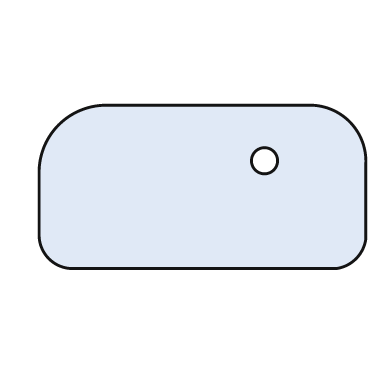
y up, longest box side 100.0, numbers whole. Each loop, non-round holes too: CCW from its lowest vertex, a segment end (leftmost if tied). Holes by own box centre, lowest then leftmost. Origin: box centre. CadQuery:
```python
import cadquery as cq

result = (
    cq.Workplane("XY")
    .moveTo(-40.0, -25.0)
    .lineTo(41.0, -25.0)
    .threePointArc((47.0, -22.0), (50.0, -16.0))
    .lineTo(50.0, 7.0)
    .threePointArc((45.0, 20.0), (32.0, 25.0))
    .lineTo(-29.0, 25.0)
    .threePointArc((-44.0, 19.0), (-50.0, 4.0))
    .lineTo(-50.0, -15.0)
    .threePointArc((-47.0, -22.0), (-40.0, -25.0))
    .close()
    .moveTo(19.0, 8.0)
    .circle(4.0)
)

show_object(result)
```